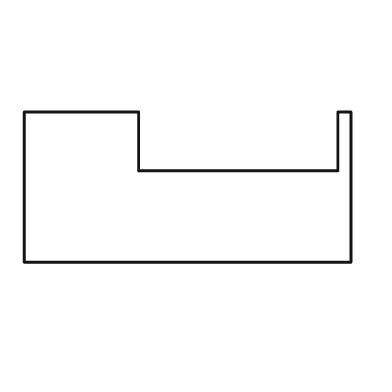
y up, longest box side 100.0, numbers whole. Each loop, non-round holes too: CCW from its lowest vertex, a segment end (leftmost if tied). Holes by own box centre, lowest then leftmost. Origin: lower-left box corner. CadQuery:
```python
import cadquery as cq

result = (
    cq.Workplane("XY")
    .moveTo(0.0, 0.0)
    .lineTo(100.0, 0.0)
    .lineTo(100.0, 46.0)
    .lineTo(96.0, 46.0)
    .lineTo(96.0, 28.0)
    .lineTo(35.0, 28.0)
    .lineTo(35.0, 46.0)
    .lineTo(0.0, 46.0)
    .close()
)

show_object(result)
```